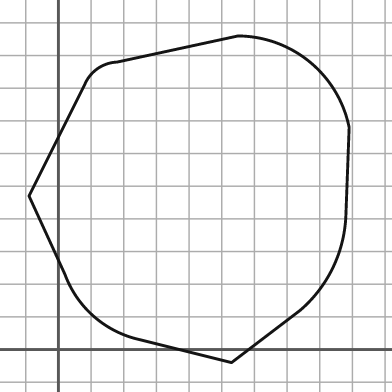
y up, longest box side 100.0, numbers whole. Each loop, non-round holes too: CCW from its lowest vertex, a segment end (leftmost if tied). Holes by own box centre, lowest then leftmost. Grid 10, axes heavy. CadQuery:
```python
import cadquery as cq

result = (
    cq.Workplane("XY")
    .moveTo(53.0, -4.0)
    .lineTo(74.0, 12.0)
    .threePointArc((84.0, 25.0), (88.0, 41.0))
    .lineTo(89.0, 68.0)
    .threePointArc((77.0, 88.0), (55.0, 96.0))
    .lineTo(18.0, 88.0)
    .threePointArc((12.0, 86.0), (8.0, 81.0))
    .lineTo(-9.0, 47.0)
    .lineTo(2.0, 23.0)
    .threePointArc((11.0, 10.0), (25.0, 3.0))
    .close()
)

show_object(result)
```